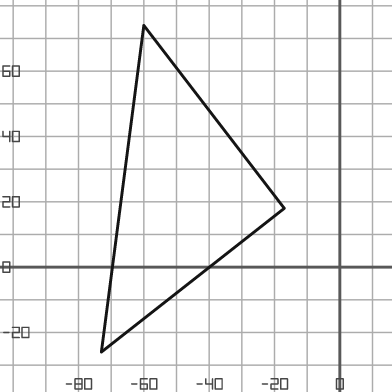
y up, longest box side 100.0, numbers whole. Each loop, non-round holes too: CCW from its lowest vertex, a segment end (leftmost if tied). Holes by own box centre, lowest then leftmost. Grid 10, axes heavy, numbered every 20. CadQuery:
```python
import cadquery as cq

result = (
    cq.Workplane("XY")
    .moveTo(-73.0, -26.0)
    .lineTo(-17.0, 18.0)
    .lineTo(-60.0, 74.0)
    .close()
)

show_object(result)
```